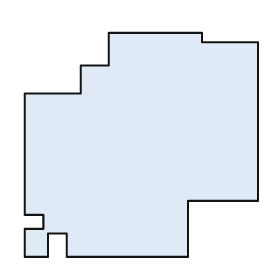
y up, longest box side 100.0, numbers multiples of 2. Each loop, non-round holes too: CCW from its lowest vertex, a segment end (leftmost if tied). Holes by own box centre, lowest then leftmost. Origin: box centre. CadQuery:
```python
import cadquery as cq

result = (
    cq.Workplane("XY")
    .moveTo(-50.0, -48.0)
    .lineTo(-40.0, -48.0)
    .lineTo(-40.0, -38.0)
    .lineTo(-32.0, -38.0)
    .lineTo(-32.0, -48.0)
    .lineTo(20.0, -48.0)
    .lineTo(20.0, -24.0)
    .lineTo(50.0, -24.0)
    .lineTo(50.0, 44.0)
    .lineTo(26.0, 44.0)
    .lineTo(26.0, 48.0)
    .lineTo(-14.0, 48.0)
    .lineTo(-14.0, 34.0)
    .lineTo(-26.0, 34.0)
    .lineTo(-26.0, 22.0)
    .lineTo(-50.0, 22.0)
    .lineTo(-50.0, -30.0)
    .lineTo(-42.0, -30.0)
    .lineTo(-42.0, -36.0)
    .lineTo(-50.0, -36.0)
    .close()
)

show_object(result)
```